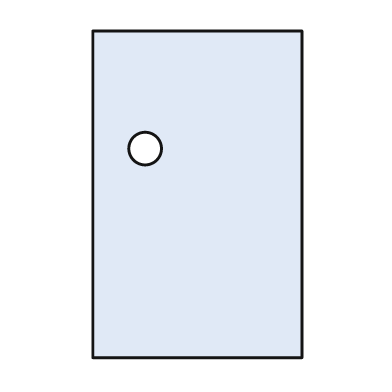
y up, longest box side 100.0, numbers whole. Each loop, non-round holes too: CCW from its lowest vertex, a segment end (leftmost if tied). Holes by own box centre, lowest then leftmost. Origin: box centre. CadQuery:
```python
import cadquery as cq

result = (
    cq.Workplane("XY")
    .moveTo(-32.0, -50.0)
    .lineTo(32.0, -50.0)
    .lineTo(32.0, 50.0)
    .lineTo(-32.0, 50.0)
    .close()
    .moveTo(-16.0, 14.0)
    .circle(5.0)
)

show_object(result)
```